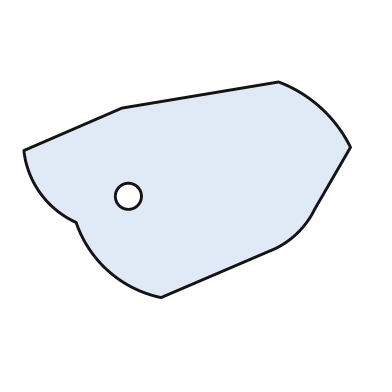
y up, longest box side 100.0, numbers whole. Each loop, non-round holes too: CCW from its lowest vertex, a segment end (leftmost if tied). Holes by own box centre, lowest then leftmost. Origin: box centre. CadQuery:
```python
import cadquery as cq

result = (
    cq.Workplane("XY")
    .moveTo(-8.0, -33.0)
    .lineTo(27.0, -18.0)
    .threePointArc((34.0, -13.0), (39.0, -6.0))
    .lineTo(50.0, 13.0)
    .threePointArc((41.0, 25.0), (28.0, 33.0))
    .lineTo(-20.0, 25.0)
    .lineTo(-50.0, 12.0)
    .threePointArc((-45.0, -1.0), (-34.0, -10.0))
    .threePointArc((-24.0, -25.0), (-8.0, -33.0))
    .close()
    .moveTo(-18.0, -2.0)
    .circle(4.0)
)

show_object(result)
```